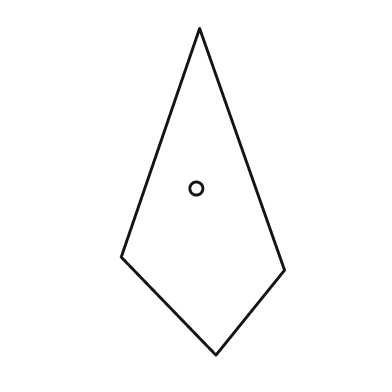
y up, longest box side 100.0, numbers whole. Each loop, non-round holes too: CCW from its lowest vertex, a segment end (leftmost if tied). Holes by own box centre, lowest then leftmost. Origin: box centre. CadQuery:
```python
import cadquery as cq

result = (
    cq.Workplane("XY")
    .moveTo(4.0, -50.0)
    .lineTo(25.0, -24.0)
    .lineTo(-1.0, 50.0)
    .lineTo(-25.0, -20.0)
    .close()
    .moveTo(-2.0, 1.0)
    .circle(2.0)
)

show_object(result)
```